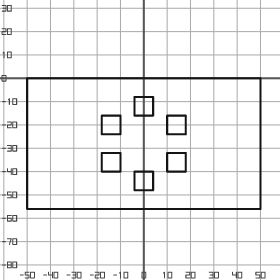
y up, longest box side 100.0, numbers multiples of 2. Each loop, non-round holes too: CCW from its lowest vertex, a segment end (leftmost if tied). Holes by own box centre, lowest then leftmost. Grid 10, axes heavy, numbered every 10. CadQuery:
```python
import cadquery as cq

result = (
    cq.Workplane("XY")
    .moveTo(-50.0, -56.0)
    .lineTo(50.0, -56.0)
    .lineTo(50.0, 0.0)
    .lineTo(-50.0, 0.0)
    .close()
    .moveTo(-4.0, -48.0)
    .lineTo(4.0, -48.0)
    .lineTo(4.0, -40.0)
    .lineTo(-4.0, -40.0)
    .close()
    .moveTo(-18.0, -40.0)
    .lineTo(-10.0, -40.0)
    .lineTo(-10.0, -32.0)
    .lineTo(-18.0, -32.0)
    .close()
    .moveTo(10.0, -40.0)
    .lineTo(18.0, -40.0)
    .lineTo(18.0, -32.0)
    .lineTo(10.0, -32.0)
    .close()
    .moveTo(-18.0, -24.0)
    .lineTo(-10.0, -24.0)
    .lineTo(-10.0, -16.0)
    .lineTo(-18.0, -16.0)
    .close()
    .moveTo(10.0, -24.0)
    .lineTo(18.0, -24.0)
    .lineTo(18.0, -16.0)
    .lineTo(10.0, -16.0)
    .close()
    .moveTo(-4.0, -16.0)
    .lineTo(4.0, -16.0)
    .lineTo(4.0, -8.0)
    .lineTo(-4.0, -8.0)
    .close()
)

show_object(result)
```